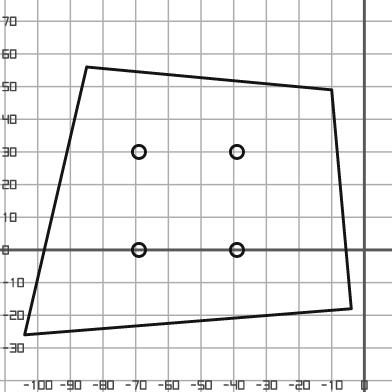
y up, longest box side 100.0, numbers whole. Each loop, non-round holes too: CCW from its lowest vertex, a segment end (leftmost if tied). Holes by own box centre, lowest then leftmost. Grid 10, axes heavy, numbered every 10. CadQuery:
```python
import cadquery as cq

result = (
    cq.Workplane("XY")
    .moveTo(-104.0, -26.0)
    .lineTo(-4.0, -18.0)
    .lineTo(-10.0, 49.0)
    .lineTo(-85.0, 56.0)
    .close()
    .moveTo(-69.0, 0.0)
    .circle(2.0)
    .moveTo(-39.0, 0.0)
    .circle(2.0)
    .moveTo(-69.0, 30.0)
    .circle(2.0)
    .moveTo(-39.0, 30.0)
    .circle(2.0)
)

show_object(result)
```